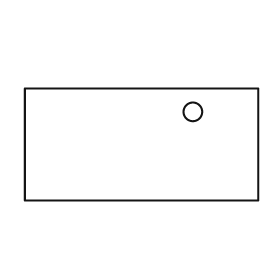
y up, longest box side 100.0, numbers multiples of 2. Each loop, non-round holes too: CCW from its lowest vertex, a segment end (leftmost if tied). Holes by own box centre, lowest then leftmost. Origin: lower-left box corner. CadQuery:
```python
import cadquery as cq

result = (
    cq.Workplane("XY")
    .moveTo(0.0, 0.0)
    .lineTo(100.0, 0.0)
    .lineTo(100.0, 48.0)
    .lineTo(0.0, 48.0)
    .close()
    .moveTo(72.0, 38.0)
    .circle(4.0)
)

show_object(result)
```